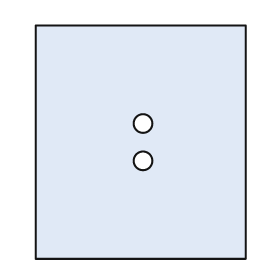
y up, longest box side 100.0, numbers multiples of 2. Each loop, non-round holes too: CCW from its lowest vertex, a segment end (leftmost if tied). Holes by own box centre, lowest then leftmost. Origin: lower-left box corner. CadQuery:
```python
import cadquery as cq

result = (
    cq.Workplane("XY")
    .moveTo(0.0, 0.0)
    .lineTo(90.0, 0.0)
    .lineTo(90.0, 100.0)
    .lineTo(0.0, 100.0)
    .close()
    .moveTo(46.0, 42.0)
    .circle(4.0)
    .moveTo(46.0, 58.0)
    .circle(4.0)
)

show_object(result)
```